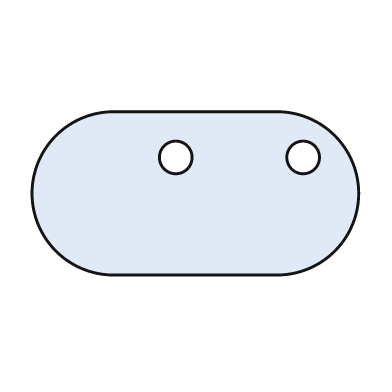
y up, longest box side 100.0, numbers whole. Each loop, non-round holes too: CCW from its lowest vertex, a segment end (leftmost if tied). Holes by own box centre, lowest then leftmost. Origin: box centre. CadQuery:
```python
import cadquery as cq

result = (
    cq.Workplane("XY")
    .moveTo(-25.0, -25.0)
    .lineTo(25.0, -25.0)
    .threePointArc((50.0, 0.0), (25.0, 25.0))
    .lineTo(-25.0, 25.0)
    .threePointArc((-50.0, 0.0), (-25.0, -25.0))
    .close()
    .moveTo(-6.0, 11.0)
    .circle(5.0)
    .moveTo(33.0, 11.0)
    .circle(5.0)
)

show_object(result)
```